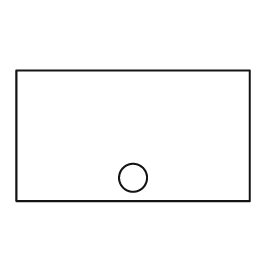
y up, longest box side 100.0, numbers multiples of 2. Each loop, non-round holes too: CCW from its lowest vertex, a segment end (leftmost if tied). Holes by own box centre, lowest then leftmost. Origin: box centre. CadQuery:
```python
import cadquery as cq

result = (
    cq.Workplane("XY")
    .moveTo(-50.0, -28.0)
    .lineTo(50.0, -28.0)
    .lineTo(50.0, 28.0)
    .lineTo(-50.0, 28.0)
    .close()
    .moveTo(0.0, -18.0)
    .circle(6.0)
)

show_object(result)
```